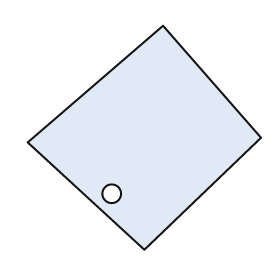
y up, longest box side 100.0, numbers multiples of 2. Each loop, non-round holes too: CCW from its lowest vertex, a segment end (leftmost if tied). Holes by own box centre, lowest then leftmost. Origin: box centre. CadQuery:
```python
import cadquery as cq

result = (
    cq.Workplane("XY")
    .moveTo(0.0, -48.0)
    .lineTo(50.0, 0.0)
    .lineTo(8.0, 48.0)
    .lineTo(-50.0, -2.0)
    .close()
    .moveTo(-14.0, -24.0)
    .circle(4.0)
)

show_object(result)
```